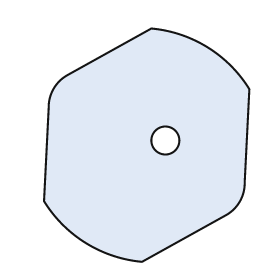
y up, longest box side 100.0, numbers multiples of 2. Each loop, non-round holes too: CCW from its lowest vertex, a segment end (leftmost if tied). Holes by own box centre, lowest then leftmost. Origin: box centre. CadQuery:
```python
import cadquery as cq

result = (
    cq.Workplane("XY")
    .moveTo(-2.0, -50.0)
    .lineTo(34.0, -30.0)
    .threePointArc((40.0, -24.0), (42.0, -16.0))
    .lineTo(44.0, 24.0)
    .threePointArc((26.0, 42.0), (2.0, 50.0))
    .lineTo(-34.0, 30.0)
    .threePointArc((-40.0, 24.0), (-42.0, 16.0))
    .lineTo(-44.0, -24.0)
    .threePointArc((-26.0, -42.0), (-2.0, -50.0))
    .close()
    .moveTo(8.0, 2.0)
    .circle(6.0)
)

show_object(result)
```